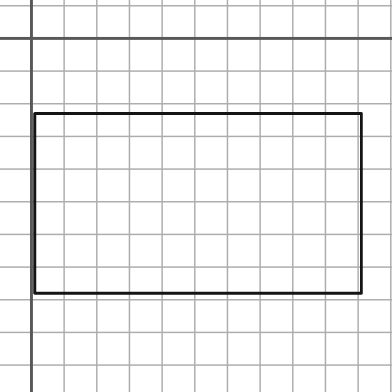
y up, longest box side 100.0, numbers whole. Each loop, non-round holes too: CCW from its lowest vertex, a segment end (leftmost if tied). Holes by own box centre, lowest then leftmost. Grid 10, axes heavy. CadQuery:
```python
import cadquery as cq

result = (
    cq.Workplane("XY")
    .moveTo(1.0, -78.0)
    .lineTo(101.0, -78.0)
    .lineTo(101.0, -23.0)
    .lineTo(1.0, -23.0)
    .close()
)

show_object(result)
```